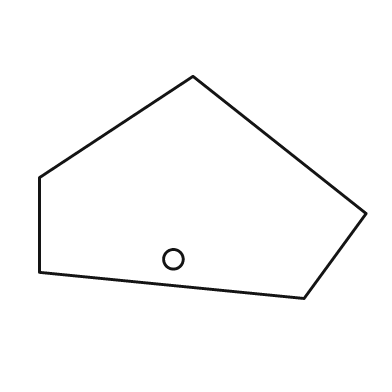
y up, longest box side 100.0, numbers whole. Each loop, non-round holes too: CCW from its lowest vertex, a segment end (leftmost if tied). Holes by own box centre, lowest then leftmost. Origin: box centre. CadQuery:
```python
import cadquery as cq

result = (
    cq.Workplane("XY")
    .moveTo(31.0, -34.0)
    .lineTo(50.0, -8.0)
    .lineTo(-3.0, 34.0)
    .lineTo(-50.0, 3.0)
    .lineTo(-50.0, -26.0)
    .close()
    .moveTo(-9.0, -22.0)
    .circle(3.0)
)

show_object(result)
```